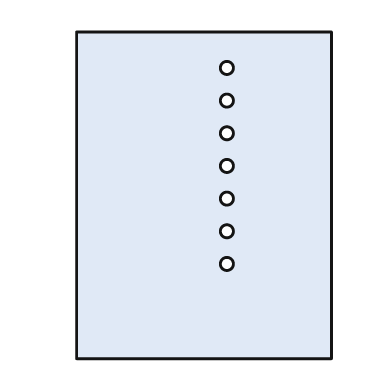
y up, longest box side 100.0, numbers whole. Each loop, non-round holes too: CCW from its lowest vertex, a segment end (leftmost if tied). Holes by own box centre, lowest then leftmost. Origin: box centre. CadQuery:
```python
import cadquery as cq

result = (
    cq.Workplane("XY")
    .moveTo(-39.0, -50.0)
    .lineTo(39.0, -50.0)
    .lineTo(39.0, 50.0)
    .lineTo(-39.0, 50.0)
    .close()
    .moveTo(7.0, -21.0)
    .circle(2.0)
    .moveTo(7.0, -11.0)
    .circle(2.0)
    .moveTo(7.0, -1.0)
    .circle(2.0)
    .moveTo(7.0, 9.0)
    .circle(2.0)
    .moveTo(7.0, 19.0)
    .circle(2.0)
    .moveTo(7.0, 29.0)
    .circle(2.0)
    .moveTo(7.0, 39.0)
    .circle(2.0)
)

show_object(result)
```